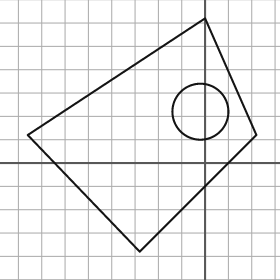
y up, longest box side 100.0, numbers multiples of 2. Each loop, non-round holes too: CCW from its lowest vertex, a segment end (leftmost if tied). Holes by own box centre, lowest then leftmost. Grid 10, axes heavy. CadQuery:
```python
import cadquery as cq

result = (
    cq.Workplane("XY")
    .moveTo(-28.0, -38.0)
    .lineTo(22.0, 12.0)
    .lineTo(0.0, 62.0)
    .lineTo(-76.0, 12.0)
    .close()
    .moveTo(-2.0, 22.0)
    .circle(12.0)
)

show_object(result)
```